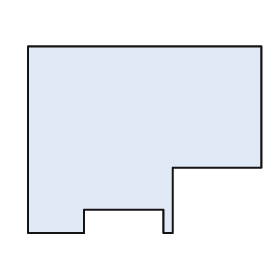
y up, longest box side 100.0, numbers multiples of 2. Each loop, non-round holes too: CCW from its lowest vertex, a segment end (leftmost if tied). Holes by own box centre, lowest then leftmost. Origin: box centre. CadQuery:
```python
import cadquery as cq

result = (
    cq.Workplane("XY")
    .moveTo(-50.0, -40.0)
    .lineTo(-26.0, -40.0)
    .lineTo(-26.0, -30.0)
    .lineTo(8.0, -30.0)
    .lineTo(8.0, -40.0)
    .lineTo(12.0, -40.0)
    .lineTo(12.0, -12.0)
    .lineTo(50.0, -12.0)
    .lineTo(50.0, 40.0)
    .lineTo(-50.0, 40.0)
    .close()
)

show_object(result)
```